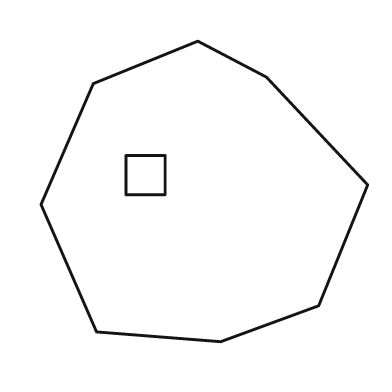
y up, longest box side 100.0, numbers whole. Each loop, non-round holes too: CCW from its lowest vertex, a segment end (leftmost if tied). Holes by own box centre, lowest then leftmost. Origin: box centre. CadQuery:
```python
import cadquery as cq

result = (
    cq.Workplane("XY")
    .moveTo(5.0, -46.0)
    .lineTo(35.0, -35.0)
    .lineTo(50.0, 2.0)
    .lineTo(19.0, 35.0)
    .lineTo(-2.0, 46.0)
    .lineTo(-34.0, 33.0)
    .lineTo(-50.0, -4.0)
    .lineTo(-33.0, -43.0)
    .close()
    .moveTo(-24.0, -1.0)
    .lineTo(-12.0, -1.0)
    .lineTo(-12.0, 11.0)
    .lineTo(-24.0, 11.0)
    .close()
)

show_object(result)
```